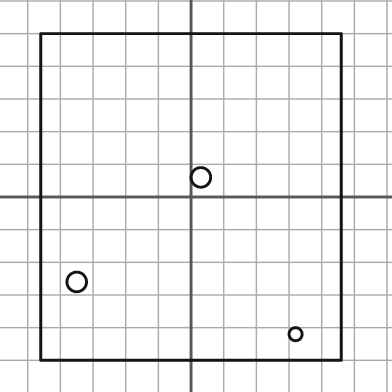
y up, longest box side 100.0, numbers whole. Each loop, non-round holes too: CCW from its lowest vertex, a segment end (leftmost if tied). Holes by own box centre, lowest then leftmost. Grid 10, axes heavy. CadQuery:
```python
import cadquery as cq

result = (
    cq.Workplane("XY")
    .moveTo(-46.0, -50.0)
    .lineTo(46.0, -50.0)
    .lineTo(46.0, 50.0)
    .lineTo(-46.0, 50.0)
    .close()
    .moveTo(32.0, -42.0)
    .circle(2.0)
    .moveTo(-35.0, -26.0)
    .circle(3.0)
    .moveTo(3.0, 6.0)
    .circle(3.0)
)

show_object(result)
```